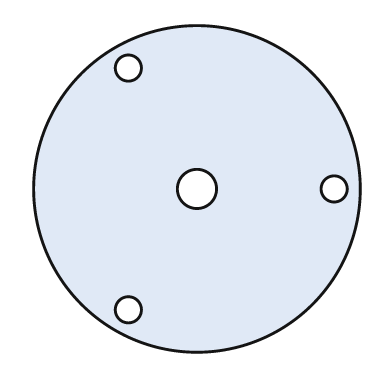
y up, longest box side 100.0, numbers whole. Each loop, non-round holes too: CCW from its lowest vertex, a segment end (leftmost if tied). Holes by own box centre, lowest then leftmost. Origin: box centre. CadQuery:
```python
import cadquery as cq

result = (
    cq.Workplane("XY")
    .moveTo(0.0, 0.0)
    .circle(50.0)
    .moveTo(-21.0, -37.0)
    .circle(4.0)
    .moveTo(0.0, 0.0)
    .circle(6.0)
    .moveTo(42.0, 0.0)
    .circle(4.0)
    .moveTo(-21.0, 37.0)
    .circle(4.0)
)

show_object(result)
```